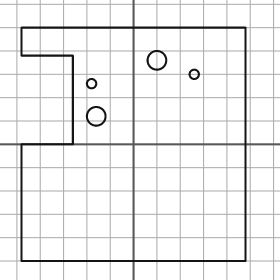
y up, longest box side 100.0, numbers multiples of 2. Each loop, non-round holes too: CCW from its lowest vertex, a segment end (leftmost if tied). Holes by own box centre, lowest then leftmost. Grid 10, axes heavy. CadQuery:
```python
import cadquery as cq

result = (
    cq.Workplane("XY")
    .moveTo(-48.0, -50.0)
    .lineTo(48.0, -50.0)
    .lineTo(48.0, 50.0)
    .lineTo(-48.0, 50.0)
    .lineTo(-48.0, 38.0)
    .lineTo(-26.0, 38.0)
    .lineTo(-26.0, 0.0)
    .lineTo(-48.0, 0.0)
    .close()
    .moveTo(-16.0, 12.0)
    .circle(4.0)
    .moveTo(-18.0, 26.0)
    .circle(2.0)
    .moveTo(26.0, 30.0)
    .circle(2.0)
    .moveTo(10.0, 36.0)
    .circle(4.0)
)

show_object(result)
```